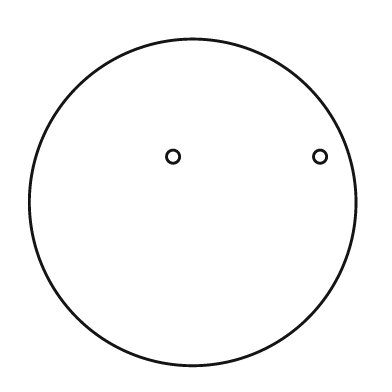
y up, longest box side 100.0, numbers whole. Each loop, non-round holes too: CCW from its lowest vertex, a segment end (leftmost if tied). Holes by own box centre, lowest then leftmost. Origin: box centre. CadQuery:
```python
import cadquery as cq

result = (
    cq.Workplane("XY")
    .moveTo(0.0, 0.0)
    .circle(50.0)
    .moveTo(-6.0, 14.0)
    .circle(2.0)
    .moveTo(39.0, 14.0)
    .circle(2.0)
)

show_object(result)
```